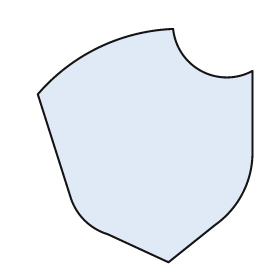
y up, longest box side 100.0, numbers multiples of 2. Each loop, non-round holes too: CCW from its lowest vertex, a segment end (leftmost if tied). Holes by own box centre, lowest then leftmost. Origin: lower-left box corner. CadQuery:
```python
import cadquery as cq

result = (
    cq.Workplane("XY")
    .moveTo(56.0, 0.0)
    .lineTo(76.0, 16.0)
    .threePointArc((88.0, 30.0), (92.0, 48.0))
    .lineTo(92.0, 82.0)
    .threePointArc((70.0, 82.0), (58.0, 100.0))
    .threePointArc((26.0, 92.0), (0.0, 72.0))
    .lineTo(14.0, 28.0)
    .threePointArc((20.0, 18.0), (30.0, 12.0))
    .close()
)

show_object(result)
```